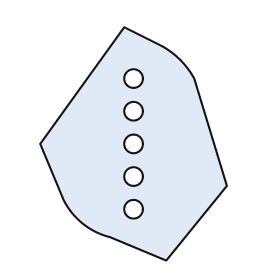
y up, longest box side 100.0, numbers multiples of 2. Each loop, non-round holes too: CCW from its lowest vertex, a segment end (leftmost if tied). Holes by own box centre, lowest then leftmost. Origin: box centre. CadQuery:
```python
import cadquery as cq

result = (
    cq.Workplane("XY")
    .moveTo(14.0, -50.0)
    .lineTo(40.0, -18.0)
    .lineTo(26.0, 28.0)
    .threePointArc((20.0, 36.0), (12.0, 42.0))
    .lineTo(-4.0, 50.0)
    .lineTo(-40.0, 0.0)
    .lineTo(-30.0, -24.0)
    .threePointArc((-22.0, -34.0), (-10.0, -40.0))
    .close()
    .moveTo(0.0, -28.0)
    .circle(4.0)
    .moveTo(0.0, -14.0)
    .circle(4.0)
    .moveTo(0.0, 0.0)
    .circle(4.0)
    .moveTo(0.0, 14.0)
    .circle(4.0)
    .moveTo(0.0, 28.0)
    .circle(4.0)
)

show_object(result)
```